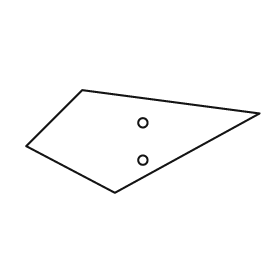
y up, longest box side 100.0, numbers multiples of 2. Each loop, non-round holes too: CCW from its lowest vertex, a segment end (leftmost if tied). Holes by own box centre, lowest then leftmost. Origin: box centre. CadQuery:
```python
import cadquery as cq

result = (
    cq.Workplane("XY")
    .moveTo(-12.0, -22.0)
    .lineTo(50.0, 12.0)
    .lineTo(-26.0, 22.0)
    .lineTo(-50.0, -2.0)
    .close()
    .moveTo(0.0, -8.0)
    .circle(2.0)
    .moveTo(0.0, 8.0)
    .circle(2.0)
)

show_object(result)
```